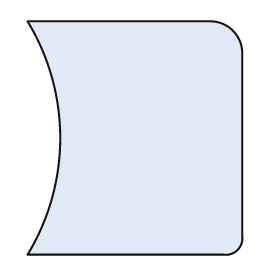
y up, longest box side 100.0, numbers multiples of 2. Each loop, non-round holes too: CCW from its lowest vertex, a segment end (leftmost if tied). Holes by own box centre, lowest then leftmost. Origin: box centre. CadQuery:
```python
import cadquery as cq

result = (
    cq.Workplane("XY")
    .moveTo(-46.0, -50.0)
    .lineTo(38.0, -50.0)
    .threePointArc((44.0, -48.0), (46.0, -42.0))
    .lineTo(46.0, 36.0)
    .threePointArc((42.0, 46.0), (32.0, 50.0))
    .lineTo(-46.0, 50.0)
    .threePointArc((-32.0, 0.0), (-46.0, -50.0))
    .close()
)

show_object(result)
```